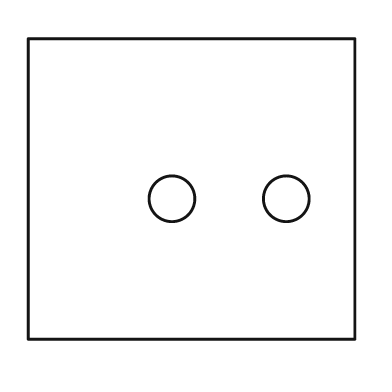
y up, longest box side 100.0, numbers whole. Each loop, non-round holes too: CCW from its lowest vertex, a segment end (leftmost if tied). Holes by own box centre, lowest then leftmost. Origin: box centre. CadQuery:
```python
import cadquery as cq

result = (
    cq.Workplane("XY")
    .moveTo(-50.0, -46.0)
    .lineTo(50.0, -46.0)
    .lineTo(50.0, 46.0)
    .lineTo(-50.0, 46.0)
    .close()
    .moveTo(-6.0, -3.0)
    .circle(7.0)
    .moveTo(29.0, -3.0)
    .circle(7.0)
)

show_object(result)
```